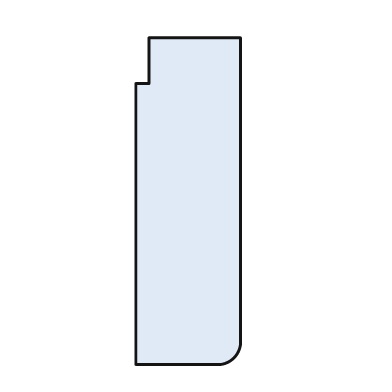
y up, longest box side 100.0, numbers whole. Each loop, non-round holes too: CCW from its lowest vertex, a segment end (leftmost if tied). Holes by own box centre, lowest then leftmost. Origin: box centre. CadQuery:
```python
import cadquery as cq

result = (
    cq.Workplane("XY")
    .moveTo(-16.0, -50.0)
    .lineTo(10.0, -50.0)
    .threePointArc((14.0, -48.0), (16.0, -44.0))
    .lineTo(16.0, 50.0)
    .lineTo(-12.0, 50.0)
    .lineTo(-12.0, 36.0)
    .lineTo(-16.0, 36.0)
    .close()
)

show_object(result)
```